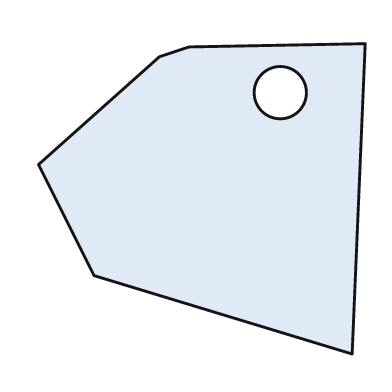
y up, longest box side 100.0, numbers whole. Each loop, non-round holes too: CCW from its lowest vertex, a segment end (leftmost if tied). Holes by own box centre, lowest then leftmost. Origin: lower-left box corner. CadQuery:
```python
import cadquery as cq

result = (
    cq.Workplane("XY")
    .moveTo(96.0, 0.0)
    .lineTo(100.0, 95.0)
    .lineTo(46.0, 94.0)
    .lineTo(37.0, 91.0)
    .lineTo(0.0, 58.0)
    .lineTo(17.0, 24.0)
    .close()
    .moveTo(74.0, 80.0)
    .circle(8.0)
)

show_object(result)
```